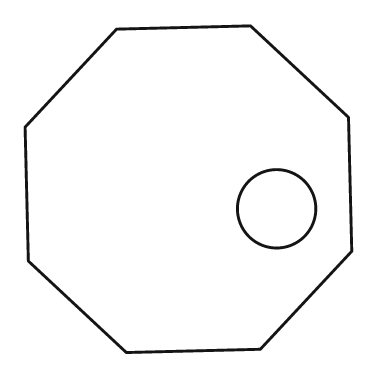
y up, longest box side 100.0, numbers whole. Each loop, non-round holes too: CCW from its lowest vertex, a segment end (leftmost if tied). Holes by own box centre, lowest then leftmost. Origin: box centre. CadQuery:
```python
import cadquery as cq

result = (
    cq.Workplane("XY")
    .moveTo(-19.0, -50.0)
    .lineTo(22.0, -49.0)
    .lineTo(50.0, -19.0)
    .lineTo(49.0, 22.0)
    .lineTo(19.0, 50.0)
    .lineTo(-22.0, 49.0)
    .lineTo(-50.0, 19.0)
    .lineTo(-49.0, -22.0)
    .close()
    .moveTo(27.0, -6.0)
    .circle(12.0)
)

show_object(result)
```